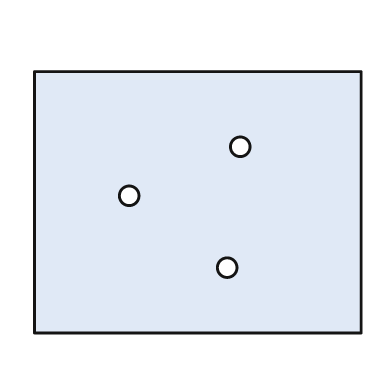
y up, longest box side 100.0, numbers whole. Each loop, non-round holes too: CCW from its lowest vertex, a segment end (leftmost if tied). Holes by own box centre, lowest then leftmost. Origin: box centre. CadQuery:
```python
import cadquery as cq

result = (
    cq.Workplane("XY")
    .moveTo(-50.0, -40.0)
    .lineTo(50.0, -40.0)
    .lineTo(50.0, 40.0)
    .lineTo(-50.0, 40.0)
    .close()
    .moveTo(9.0, -20.0)
    .circle(3.0)
    .moveTo(-21.0, 2.0)
    .circle(3.0)
    .moveTo(13.0, 17.0)
    .circle(3.0)
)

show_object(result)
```